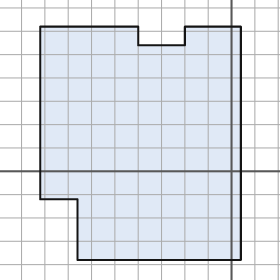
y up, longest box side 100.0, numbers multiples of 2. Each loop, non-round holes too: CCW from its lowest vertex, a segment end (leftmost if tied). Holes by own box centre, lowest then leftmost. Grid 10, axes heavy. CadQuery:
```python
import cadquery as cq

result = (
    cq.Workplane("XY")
    .moveTo(-66.0, -38.0)
    .lineTo(4.0, -38.0)
    .lineTo(4.0, 62.0)
    .lineTo(-20.0, 62.0)
    .lineTo(-20.0, 54.0)
    .lineTo(-40.0, 54.0)
    .lineTo(-40.0, 62.0)
    .lineTo(-82.0, 62.0)
    .lineTo(-82.0, -12.0)
    .lineTo(-66.0, -12.0)
    .close()
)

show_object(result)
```